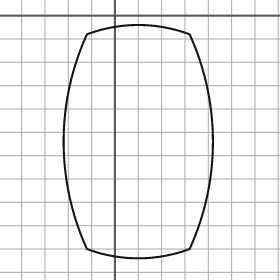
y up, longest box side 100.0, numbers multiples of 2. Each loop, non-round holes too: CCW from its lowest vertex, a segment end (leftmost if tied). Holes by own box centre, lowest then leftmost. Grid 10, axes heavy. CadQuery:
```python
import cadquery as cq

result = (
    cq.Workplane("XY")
    .moveTo(-12.0, -100.0)
    .threePointArc((10.0, -104.0), (32.0, -100.0))
    .threePointArc((42.0, -54.0), (32.0, -8.0))
    .threePointArc((10.0, -4.0), (-12.0, -8.0))
    .threePointArc((-22.0, -54.0), (-12.0, -100.0))
    .close()
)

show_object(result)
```